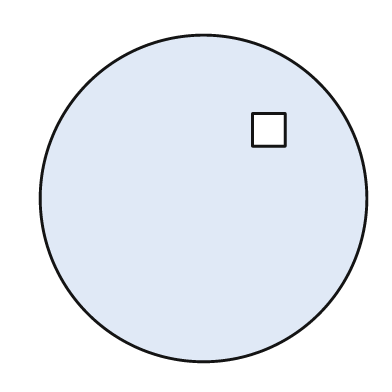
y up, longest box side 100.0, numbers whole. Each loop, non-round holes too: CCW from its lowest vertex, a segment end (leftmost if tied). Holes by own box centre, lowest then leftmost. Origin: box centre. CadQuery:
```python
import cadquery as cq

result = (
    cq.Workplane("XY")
    .moveTo(0.0, 0.0)
    .circle(50.0)
    .moveTo(15.0, 16.0)
    .lineTo(25.0, 16.0)
    .lineTo(25.0, 26.0)
    .lineTo(15.0, 26.0)
    .close()
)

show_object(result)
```